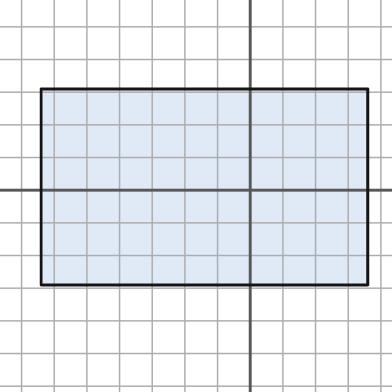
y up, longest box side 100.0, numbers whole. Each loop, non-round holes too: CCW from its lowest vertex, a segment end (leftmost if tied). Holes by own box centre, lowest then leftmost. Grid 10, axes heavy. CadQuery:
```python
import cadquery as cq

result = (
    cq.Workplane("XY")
    .moveTo(-64.0, -29.0)
    .lineTo(36.0, -29.0)
    .lineTo(36.0, 31.0)
    .lineTo(-64.0, 31.0)
    .close()
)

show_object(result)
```